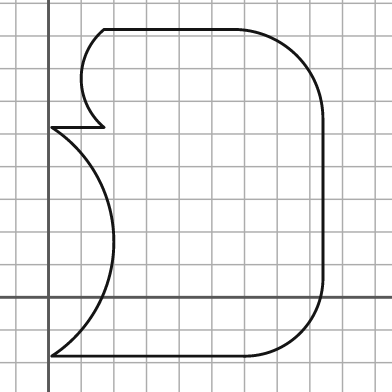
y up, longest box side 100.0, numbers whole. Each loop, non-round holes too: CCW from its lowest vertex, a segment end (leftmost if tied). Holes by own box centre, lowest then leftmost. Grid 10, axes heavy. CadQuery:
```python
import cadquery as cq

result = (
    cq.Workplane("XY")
    .moveTo(1.0, -18.0)
    .lineTo(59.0, -18.0)
    .threePointArc((77.0, -11.0), (84.0, 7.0))
    .lineTo(84.0, 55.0)
    .threePointArc((76.0, 74.0), (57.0, 82.0))
    .lineTo(17.0, 82.0)
    .threePointArc((10.0, 67.0), (17.0, 52.0))
    .lineTo(1.0, 52.0)
    .threePointArc((20.0, 17.0), (1.0, -18.0))
    .close()
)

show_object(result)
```